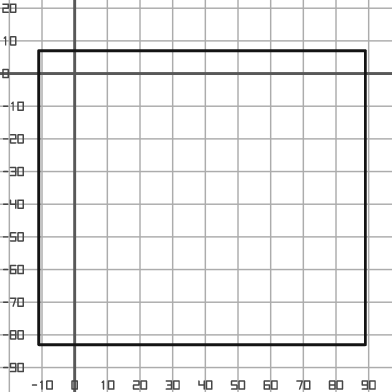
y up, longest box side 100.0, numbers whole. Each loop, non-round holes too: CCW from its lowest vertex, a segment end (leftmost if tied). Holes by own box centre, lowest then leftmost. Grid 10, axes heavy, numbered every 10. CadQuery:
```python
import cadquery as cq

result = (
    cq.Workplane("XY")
    .moveTo(-11.0, -83.0)
    .lineTo(89.0, -83.0)
    .lineTo(89.0, 7.0)
    .lineTo(-11.0, 7.0)
    .close()
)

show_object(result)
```